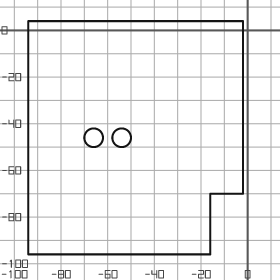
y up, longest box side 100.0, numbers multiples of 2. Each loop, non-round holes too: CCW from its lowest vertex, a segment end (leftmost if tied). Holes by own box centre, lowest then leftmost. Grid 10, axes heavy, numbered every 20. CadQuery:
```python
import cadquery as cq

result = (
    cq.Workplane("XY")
    .moveTo(-94.0, -96.0)
    .lineTo(-16.0, -96.0)
    .lineTo(-16.0, -70.0)
    .lineTo(-2.0, -70.0)
    .lineTo(-2.0, 4.0)
    .lineTo(-94.0, 4.0)
    .close()
    .moveTo(-66.0, -46.0)
    .circle(4.0)
    .moveTo(-54.0, -46.0)
    .circle(4.0)
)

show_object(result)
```